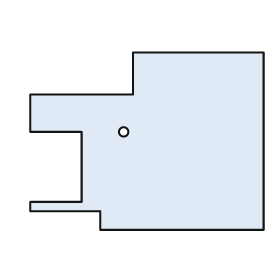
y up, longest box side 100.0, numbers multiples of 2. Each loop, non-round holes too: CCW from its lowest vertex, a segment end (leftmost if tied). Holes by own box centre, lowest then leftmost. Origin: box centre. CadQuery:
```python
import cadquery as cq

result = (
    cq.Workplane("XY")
    .moveTo(-20.0, -38.0)
    .lineTo(50.0, -38.0)
    .lineTo(50.0, 38.0)
    .lineTo(-6.0, 38.0)
    .lineTo(-6.0, 20.0)
    .lineTo(-50.0, 20.0)
    .lineTo(-50.0, 4.0)
    .lineTo(-28.0, 4.0)
    .lineTo(-28.0, -26.0)
    .lineTo(-50.0, -26.0)
    .lineTo(-50.0, -30.0)
    .lineTo(-20.0, -30.0)
    .close()
    .moveTo(-10.0, 4.0)
    .circle(2.0)
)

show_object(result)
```